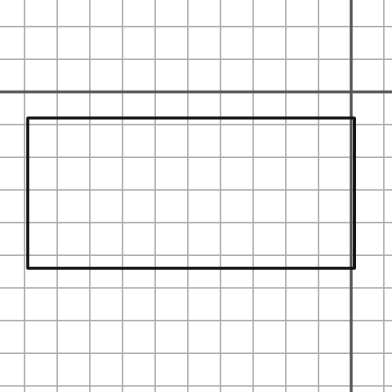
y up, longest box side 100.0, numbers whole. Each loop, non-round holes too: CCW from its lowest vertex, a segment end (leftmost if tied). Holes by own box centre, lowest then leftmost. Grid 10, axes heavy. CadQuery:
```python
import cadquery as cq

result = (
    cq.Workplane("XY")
    .moveTo(-99.0, -54.0)
    .lineTo(1.0, -54.0)
    .lineTo(1.0, -8.0)
    .lineTo(-99.0, -8.0)
    .close()
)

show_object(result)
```